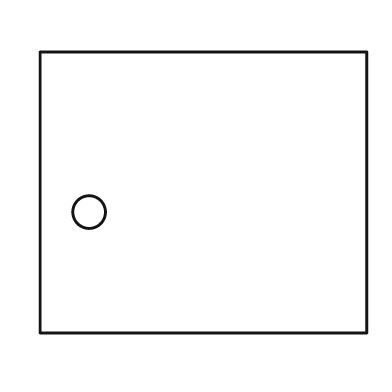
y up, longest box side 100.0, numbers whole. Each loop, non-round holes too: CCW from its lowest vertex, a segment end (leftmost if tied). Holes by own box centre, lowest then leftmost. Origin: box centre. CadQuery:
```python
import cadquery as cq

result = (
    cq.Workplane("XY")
    .moveTo(-50.0, -43.0)
    .lineTo(50.0, -43.0)
    .lineTo(50.0, 43.0)
    .lineTo(-50.0, 43.0)
    .close()
    .moveTo(-35.0, -6.0)
    .circle(5.0)
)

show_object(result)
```